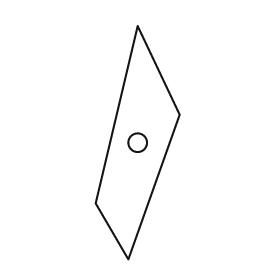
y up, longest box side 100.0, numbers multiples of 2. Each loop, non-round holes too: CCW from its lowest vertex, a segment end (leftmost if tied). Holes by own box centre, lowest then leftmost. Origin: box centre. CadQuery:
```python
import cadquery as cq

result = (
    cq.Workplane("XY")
    .moveTo(-4.0, -50.0)
    .lineTo(18.0, 12.0)
    .lineTo(0.0, 50.0)
    .lineTo(-18.0, -26.0)
    .close()
    .moveTo(0.0, 0.0)
    .circle(4.0)
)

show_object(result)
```